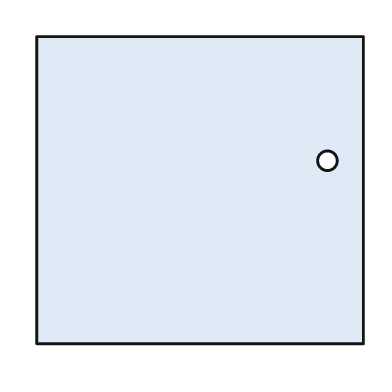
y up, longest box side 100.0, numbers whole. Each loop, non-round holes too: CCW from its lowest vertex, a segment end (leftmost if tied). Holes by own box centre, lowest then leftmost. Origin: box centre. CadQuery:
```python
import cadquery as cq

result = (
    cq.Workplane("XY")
    .moveTo(-50.0, -47.0)
    .lineTo(50.0, -47.0)
    .lineTo(50.0, 47.0)
    .lineTo(-50.0, 47.0)
    .close()
    .moveTo(39.0, 9.0)
    .circle(3.0)
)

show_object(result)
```